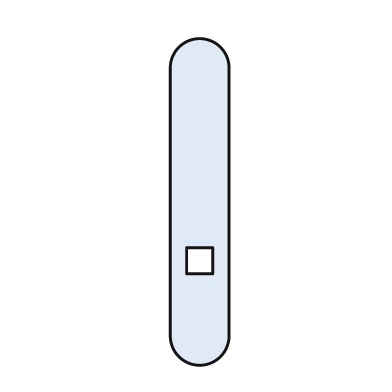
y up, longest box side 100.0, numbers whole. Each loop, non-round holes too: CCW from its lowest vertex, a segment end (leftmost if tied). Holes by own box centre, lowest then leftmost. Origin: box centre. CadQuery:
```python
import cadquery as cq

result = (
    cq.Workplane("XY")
    .moveTo(-9.0, -41.0)
    .threePointArc((0.0, -50.0), (9.0, -41.0))
    .lineTo(9.0, 41.0)
    .threePointArc((0.0, 50.0), (-9.0, 41.0))
    .close()
    .moveTo(-4.0, -22.0)
    .lineTo(4.0, -22.0)
    .lineTo(4.0, -14.0)
    .lineTo(-4.0, -14.0)
    .close()
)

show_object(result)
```